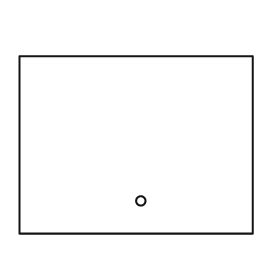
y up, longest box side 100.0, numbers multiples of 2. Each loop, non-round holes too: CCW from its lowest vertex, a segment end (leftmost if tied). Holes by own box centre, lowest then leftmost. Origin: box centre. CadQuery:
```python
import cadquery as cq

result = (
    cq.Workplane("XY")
    .moveTo(-50.0, -38.0)
    .lineTo(50.0, -38.0)
    .lineTo(50.0, 38.0)
    .lineTo(-50.0, 38.0)
    .close()
    .moveTo(2.0, -24.0)
    .circle(2.0)
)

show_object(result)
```